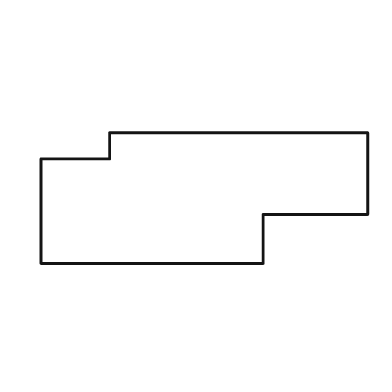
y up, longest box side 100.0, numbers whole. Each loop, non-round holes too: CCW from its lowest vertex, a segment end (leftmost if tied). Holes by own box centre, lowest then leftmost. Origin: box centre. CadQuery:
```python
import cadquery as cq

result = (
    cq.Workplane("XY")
    .moveTo(-50.0, -20.0)
    .lineTo(18.0, -20.0)
    .lineTo(18.0, -5.0)
    .lineTo(50.0, -5.0)
    .lineTo(50.0, 20.0)
    .lineTo(-29.0, 20.0)
    .lineTo(-29.0, 12.0)
    .lineTo(-50.0, 12.0)
    .close()
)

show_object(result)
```